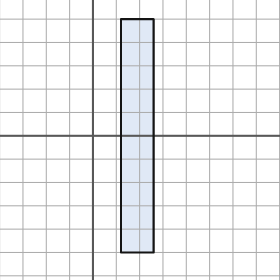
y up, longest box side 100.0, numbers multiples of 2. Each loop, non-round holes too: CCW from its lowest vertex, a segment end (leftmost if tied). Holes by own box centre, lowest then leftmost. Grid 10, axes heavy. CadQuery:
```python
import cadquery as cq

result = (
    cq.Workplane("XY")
    .moveTo(12.0, -50.0)
    .lineTo(26.0, -50.0)
    .lineTo(26.0, 50.0)
    .lineTo(12.0, 50.0)
    .close()
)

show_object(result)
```